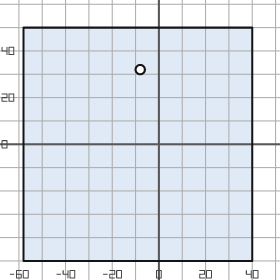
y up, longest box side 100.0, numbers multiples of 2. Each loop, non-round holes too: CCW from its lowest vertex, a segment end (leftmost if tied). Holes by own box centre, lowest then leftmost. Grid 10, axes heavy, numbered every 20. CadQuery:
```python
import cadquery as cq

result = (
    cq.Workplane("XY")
    .moveTo(-58.0, -50.0)
    .lineTo(40.0, -50.0)
    .lineTo(40.0, 50.0)
    .lineTo(-58.0, 50.0)
    .close()
    .moveTo(-8.0, 32.0)
    .circle(2.0)
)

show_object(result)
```